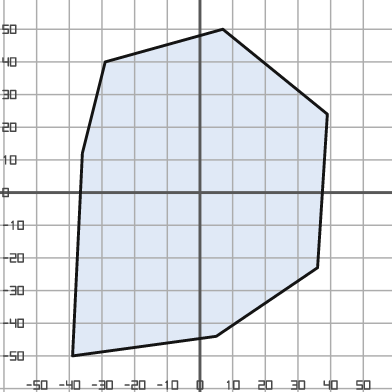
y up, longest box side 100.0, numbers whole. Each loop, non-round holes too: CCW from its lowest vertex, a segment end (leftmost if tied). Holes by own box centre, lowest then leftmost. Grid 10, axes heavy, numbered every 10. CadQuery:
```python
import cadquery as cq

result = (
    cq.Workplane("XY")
    .moveTo(-39.0, -50.0)
    .lineTo(5.0, -44.0)
    .lineTo(36.0, -23.0)
    .lineTo(39.0, 24.0)
    .lineTo(7.0, 50.0)
    .lineTo(-29.0, 40.0)
    .lineTo(-36.0, 12.0)
    .close()
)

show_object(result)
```